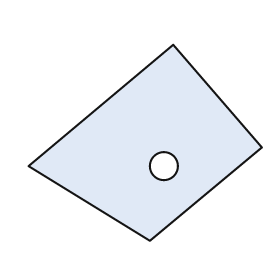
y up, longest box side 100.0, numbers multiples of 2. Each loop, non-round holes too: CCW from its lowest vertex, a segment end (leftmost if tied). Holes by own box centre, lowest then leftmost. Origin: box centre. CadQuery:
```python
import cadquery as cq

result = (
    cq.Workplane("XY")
    .moveTo(2.0, -42.0)
    .lineTo(50.0, -2.0)
    .lineTo(12.0, 42.0)
    .lineTo(-50.0, -10.0)
    .close()
    .moveTo(8.0, -10.0)
    .circle(6.0)
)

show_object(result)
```